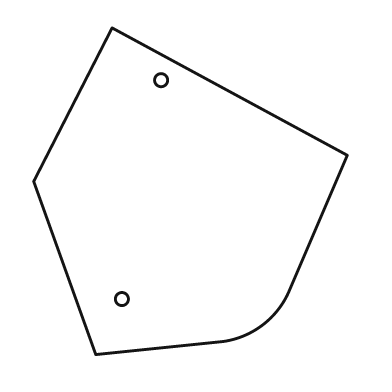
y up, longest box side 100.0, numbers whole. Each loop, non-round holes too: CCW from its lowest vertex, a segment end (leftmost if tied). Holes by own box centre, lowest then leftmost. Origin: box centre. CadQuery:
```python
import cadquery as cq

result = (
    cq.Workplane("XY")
    .moveTo(-29.0, -50.0)
    .lineTo(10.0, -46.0)
    .threePointArc((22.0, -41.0), (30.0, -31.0))
    .lineTo(48.0, 11.0)
    .lineTo(-24.0, 50.0)
    .lineTo(-48.0, 3.0)
    .close()
    .moveTo(-21.0, -33.0)
    .circle(2.0)
    .moveTo(-9.0, 34.0)
    .circle(2.0)
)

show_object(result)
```